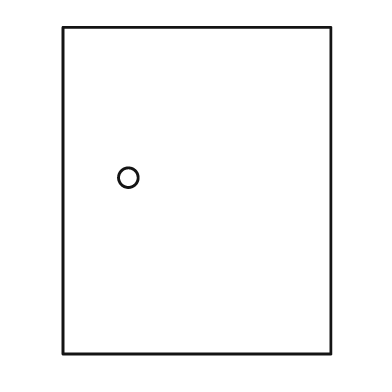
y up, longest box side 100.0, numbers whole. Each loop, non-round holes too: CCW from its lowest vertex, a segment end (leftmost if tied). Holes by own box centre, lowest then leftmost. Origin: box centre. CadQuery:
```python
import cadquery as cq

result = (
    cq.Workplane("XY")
    .moveTo(-41.0, -50.0)
    .lineTo(41.0, -50.0)
    .lineTo(41.0, 50.0)
    .lineTo(-41.0, 50.0)
    .close()
    .moveTo(-21.0, 4.0)
    .circle(3.0)
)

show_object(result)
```